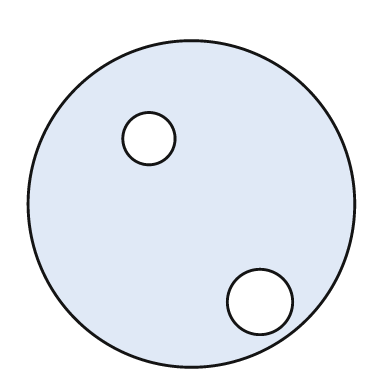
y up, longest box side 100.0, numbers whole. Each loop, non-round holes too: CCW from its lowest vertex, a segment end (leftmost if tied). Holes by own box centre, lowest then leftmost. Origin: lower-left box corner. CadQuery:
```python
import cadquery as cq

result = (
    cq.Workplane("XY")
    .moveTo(50.0, 50.0)
    .circle(50.0)
    .moveTo(71.0, 20.0)
    .circle(10.0)
    .moveTo(37.0, 70.0)
    .circle(8.0)
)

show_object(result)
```